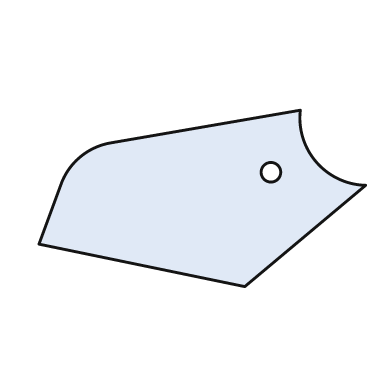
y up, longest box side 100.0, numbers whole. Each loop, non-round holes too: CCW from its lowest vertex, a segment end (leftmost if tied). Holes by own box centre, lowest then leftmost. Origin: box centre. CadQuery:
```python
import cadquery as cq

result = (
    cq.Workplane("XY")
    .moveTo(13.0, -27.0)
    .lineTo(50.0, 4.0)
    .threePointArc((35.0, 11.0), (30.0, 27.0))
    .lineTo(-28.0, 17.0)
    .threePointArc((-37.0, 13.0), (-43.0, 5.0))
    .lineTo(-50.0, -14.0)
    .close()
    .moveTo(21.0, 8.0)
    .circle(3.0)
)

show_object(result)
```